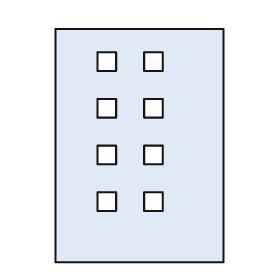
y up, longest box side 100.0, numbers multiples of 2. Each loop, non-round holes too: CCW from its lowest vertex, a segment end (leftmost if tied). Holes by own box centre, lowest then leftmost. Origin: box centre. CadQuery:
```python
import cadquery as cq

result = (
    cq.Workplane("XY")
    .moveTo(-36.0, -50.0)
    .lineTo(36.0, -50.0)
    .lineTo(36.0, 50.0)
    .lineTo(-36.0, 50.0)
    .close()
    .moveTo(-18.0, -28.0)
    .lineTo(-10.0, -28.0)
    .lineTo(-10.0, -20.0)
    .lineTo(-18.0, -20.0)
    .close()
    .moveTo(2.0, -28.0)
    .lineTo(10.0, -28.0)
    .lineTo(10.0, -20.0)
    .lineTo(2.0, -20.0)
    .close()
    .moveTo(-18.0, -8.0)
    .lineTo(-10.0, -8.0)
    .lineTo(-10.0, 0.0)
    .lineTo(-18.0, 0.0)
    .close()
    .moveTo(2.0, -8.0)
    .lineTo(10.0, -8.0)
    .lineTo(10.0, 0.0)
    .lineTo(2.0, 0.0)
    .close()
    .moveTo(-18.0, 12.0)
    .lineTo(-10.0, 12.0)
    .lineTo(-10.0, 20.0)
    .lineTo(-18.0, 20.0)
    .close()
    .moveTo(2.0, 12.0)
    .lineTo(10.0, 12.0)
    .lineTo(10.0, 20.0)
    .lineTo(2.0, 20.0)
    .close()
    .moveTo(-18.0, 32.0)
    .lineTo(-10.0, 32.0)
    .lineTo(-10.0, 40.0)
    .lineTo(-18.0, 40.0)
    .close()
    .moveTo(2.0, 32.0)
    .lineTo(10.0, 32.0)
    .lineTo(10.0, 40.0)
    .lineTo(2.0, 40.0)
    .close()
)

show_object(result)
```